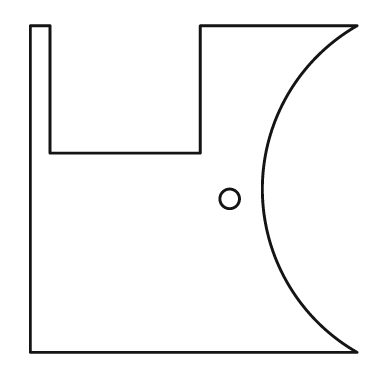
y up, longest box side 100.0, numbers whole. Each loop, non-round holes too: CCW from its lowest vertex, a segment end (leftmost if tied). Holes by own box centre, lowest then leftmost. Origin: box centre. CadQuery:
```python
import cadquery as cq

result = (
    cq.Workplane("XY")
    .moveTo(-50.0, -50.0)
    .lineTo(50.0, -50.0)
    .threePointArc((21.0, 0.0), (50.0, 50.0))
    .lineTo(2.0, 50.0)
    .lineTo(2.0, 11.0)
    .lineTo(-44.0, 11.0)
    .lineTo(-44.0, 50.0)
    .lineTo(-50.0, 50.0)
    .close()
    .moveTo(11.0, -3.0)
    .circle(3.0)
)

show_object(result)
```